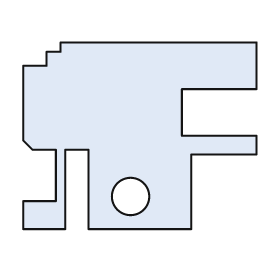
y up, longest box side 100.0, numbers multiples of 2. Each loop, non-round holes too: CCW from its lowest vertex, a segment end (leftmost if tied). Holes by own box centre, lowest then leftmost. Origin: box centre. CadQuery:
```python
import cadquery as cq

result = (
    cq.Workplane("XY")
    .moveTo(-50.0, -40.0)
    .lineTo(-32.0, -40.0)
    .lineTo(-32.0, -6.0)
    .lineTo(-22.0, -6.0)
    .lineTo(-22.0, -40.0)
    .lineTo(22.0, -40.0)
    .lineTo(22.0, -8.0)
    .lineTo(50.0, -8.0)
    .lineTo(50.0, 0.0)
    .lineTo(18.0, 0.0)
    .lineTo(18.0, 20.0)
    .lineTo(50.0, 20.0)
    .lineTo(50.0, 40.0)
    .lineTo(-34.0, 40.0)
    .lineTo(-34.0, 36.0)
    .lineTo(-40.0, 36.0)
    .lineTo(-40.0, 30.0)
    .lineTo(-50.0, 30.0)
    .lineTo(-50.0, -2.0)
    .lineTo(-46.0, -6.0)
    .lineTo(-36.0, -6.0)
    .lineTo(-36.0, -28.0)
    .lineTo(-50.0, -28.0)
    .close()
    .moveTo(-4.0, -26.0)
    .circle(8.0)
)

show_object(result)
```